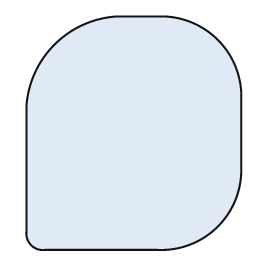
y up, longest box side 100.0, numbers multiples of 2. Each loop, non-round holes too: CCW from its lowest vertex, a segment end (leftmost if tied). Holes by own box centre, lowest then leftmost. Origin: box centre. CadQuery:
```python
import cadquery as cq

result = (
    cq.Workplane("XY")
    .moveTo(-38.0, -50.0)
    .lineTo(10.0, -50.0)
    .threePointArc((36.0, -40.0), (46.0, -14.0))
    .lineTo(46.0, 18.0)
    .threePointArc((36.0, 40.0), (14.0, 50.0))
    .lineTo(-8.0, 50.0)
    .threePointArc((-34.0, 38.0), (-46.0, 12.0))
    .lineTo(-46.0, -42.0)
    .threePointArc((-44.0, -48.0), (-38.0, -50.0))
    .close()
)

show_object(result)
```